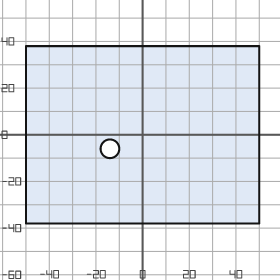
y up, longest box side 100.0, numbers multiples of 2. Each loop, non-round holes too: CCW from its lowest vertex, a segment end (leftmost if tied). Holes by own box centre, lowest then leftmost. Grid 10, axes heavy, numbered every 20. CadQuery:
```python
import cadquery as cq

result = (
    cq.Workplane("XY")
    .moveTo(-50.0, -38.0)
    .lineTo(50.0, -38.0)
    .lineTo(50.0, 38.0)
    .lineTo(-50.0, 38.0)
    .close()
    .moveTo(-14.0, -6.0)
    .circle(4.0)
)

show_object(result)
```